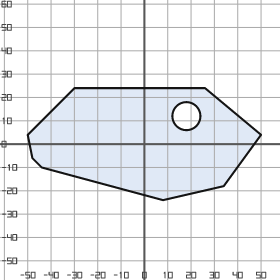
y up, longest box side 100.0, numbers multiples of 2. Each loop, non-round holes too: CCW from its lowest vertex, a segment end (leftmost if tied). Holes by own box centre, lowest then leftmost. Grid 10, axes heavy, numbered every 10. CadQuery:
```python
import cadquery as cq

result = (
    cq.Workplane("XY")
    .moveTo(8.0, -24.0)
    .lineTo(34.0, -18.0)
    .lineTo(50.0, 4.0)
    .lineTo(26.0, 24.0)
    .lineTo(-30.0, 24.0)
    .lineTo(-50.0, 4.0)
    .lineTo(-48.0, -6.0)
    .lineTo(-44.0, -10.0)
    .close()
    .moveTo(18.0, 12.0)
    .circle(6.0)
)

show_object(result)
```